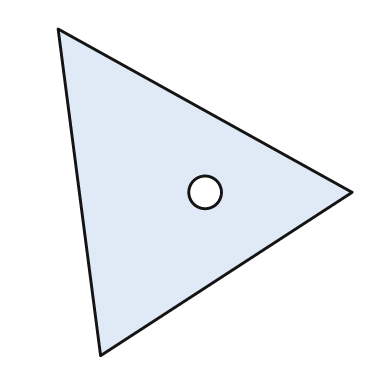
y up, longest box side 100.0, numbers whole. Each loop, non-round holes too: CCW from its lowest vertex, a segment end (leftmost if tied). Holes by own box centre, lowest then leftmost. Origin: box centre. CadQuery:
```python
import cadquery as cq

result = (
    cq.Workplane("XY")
    .moveTo(-32.0, -50.0)
    .lineTo(45.0, 0.0)
    .lineTo(-45.0, 50.0)
    .close()
    .moveTo(0.0, 0.0)
    .circle(5.0)
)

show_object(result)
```